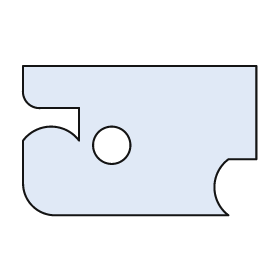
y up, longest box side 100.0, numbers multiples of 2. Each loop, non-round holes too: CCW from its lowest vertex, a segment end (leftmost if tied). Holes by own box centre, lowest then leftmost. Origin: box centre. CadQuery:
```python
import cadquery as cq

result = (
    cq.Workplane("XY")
    .moveTo(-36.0, -32.0)
    .lineTo(38.0, -32.0)
    .threePointArc((32.0, -20.0), (38.0, -8.0))
    .lineTo(50.0, -8.0)
    .lineTo(50.0, 32.0)
    .lineTo(-50.0, 32.0)
    .lineTo(-50.0, 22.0)
    .threePointArc((-48.0, 16.0), (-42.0, 14.0))
    .lineTo(-26.0, 14.0)
    .lineTo(-26.0, 0.0)
    .threePointArc((-38.0, 6.0), (-50.0, 0.0))
    .lineTo(-50.0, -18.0)
    .threePointArc((-46.0, -28.0), (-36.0, -32.0))
    .close()
    .moveTo(-12.0, -2.0)
    .circle(8.0)
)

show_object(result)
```